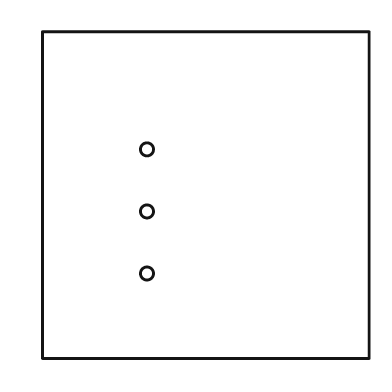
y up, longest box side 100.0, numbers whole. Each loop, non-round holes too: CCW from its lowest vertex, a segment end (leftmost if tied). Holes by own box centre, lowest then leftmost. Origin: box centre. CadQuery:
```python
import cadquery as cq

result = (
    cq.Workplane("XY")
    .moveTo(-50.0, -50.0)
    .lineTo(50.0, -50.0)
    .lineTo(50.0, 50.0)
    .lineTo(-50.0, 50.0)
    .close()
    .moveTo(-18.0, -24.0)
    .circle(2.0)
    .moveTo(-18.0, -5.0)
    .circle(2.0)
    .moveTo(-18.0, 14.0)
    .circle(2.0)
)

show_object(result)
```